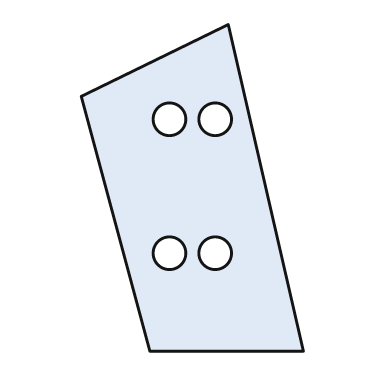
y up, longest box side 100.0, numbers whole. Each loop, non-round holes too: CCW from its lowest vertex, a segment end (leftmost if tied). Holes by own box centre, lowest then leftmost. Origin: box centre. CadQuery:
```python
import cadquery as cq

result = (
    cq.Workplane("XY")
    .moveTo(-13.0, -50.0)
    .lineTo(34.0, -50.0)
    .lineTo(11.0, 50.0)
    .lineTo(-34.0, 28.0)
    .close()
    .moveTo(-7.0, -20.0)
    .circle(5.0)
    .moveTo(7.0, -20.0)
    .circle(5.0)
    .moveTo(-7.0, 21.0)
    .circle(5.0)
    .moveTo(7.0, 21.0)
    .circle(5.0)
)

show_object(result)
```